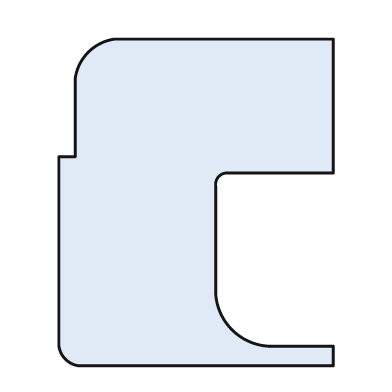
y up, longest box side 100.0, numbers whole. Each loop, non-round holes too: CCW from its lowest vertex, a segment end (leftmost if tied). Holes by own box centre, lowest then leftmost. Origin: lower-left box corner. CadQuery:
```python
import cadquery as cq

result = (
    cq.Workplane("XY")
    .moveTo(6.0, 0.0)
    .lineTo(84.0, 0.0)
    .lineTo(84.0, 6.0)
    .lineTo(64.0, 6.0)
    .threePointArc((53.0, 11.0), (48.0, 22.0))
    .lineTo(48.0, 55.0)
    .threePointArc((49.0, 58.0), (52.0, 59.0))
    .lineTo(84.0, 59.0)
    .lineTo(84.0, 100.0)
    .lineTo(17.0, 100.0)
    .threePointArc((9.0, 96.0), (5.0, 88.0))
    .lineTo(5.0, 64.0)
    .lineTo(0.0, 64.0)
    .lineTo(0.0, 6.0)
    .threePointArc((2.0, 2.0), (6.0, 0.0))
    .close()
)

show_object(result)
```